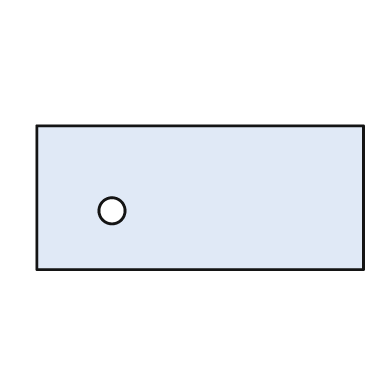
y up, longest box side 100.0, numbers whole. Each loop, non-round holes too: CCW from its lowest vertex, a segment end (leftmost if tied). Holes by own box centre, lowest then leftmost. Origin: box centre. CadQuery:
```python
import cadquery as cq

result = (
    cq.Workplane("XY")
    .moveTo(-50.0, -22.0)
    .lineTo(50.0, -22.0)
    .lineTo(50.0, 22.0)
    .lineTo(-50.0, 22.0)
    .close()
    .moveTo(-27.0, -4.0)
    .circle(4.0)
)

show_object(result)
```